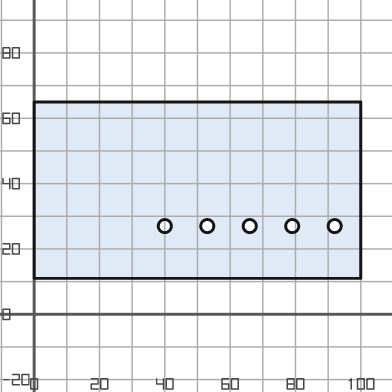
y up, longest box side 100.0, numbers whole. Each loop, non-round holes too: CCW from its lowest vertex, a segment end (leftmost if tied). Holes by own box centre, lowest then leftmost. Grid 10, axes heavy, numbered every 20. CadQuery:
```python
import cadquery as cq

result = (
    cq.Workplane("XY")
    .moveTo(0.0, 11.0)
    .lineTo(100.0, 11.0)
    .lineTo(100.0, 65.0)
    .lineTo(0.0, 65.0)
    .close()
    .moveTo(40.0, 27.0)
    .circle(2.0)
    .moveTo(53.0, 27.0)
    .circle(2.0)
    .moveTo(66.0, 27.0)
    .circle(2.0)
    .moveTo(79.0, 27.0)
    .circle(2.0)
    .moveTo(92.0, 27.0)
    .circle(2.0)
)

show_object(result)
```